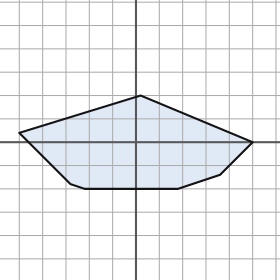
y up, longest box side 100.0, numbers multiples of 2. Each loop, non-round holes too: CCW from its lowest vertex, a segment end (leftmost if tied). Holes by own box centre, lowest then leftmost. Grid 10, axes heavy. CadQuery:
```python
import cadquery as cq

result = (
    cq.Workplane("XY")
    .moveTo(-22.0, -20.0)
    .lineTo(18.0, -20.0)
    .lineTo(36.0, -14.0)
    .lineTo(50.0, 0.0)
    .lineTo(2.0, 20.0)
    .lineTo(-50.0, 4.0)
    .lineTo(-28.0, -18.0)
    .close()
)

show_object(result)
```